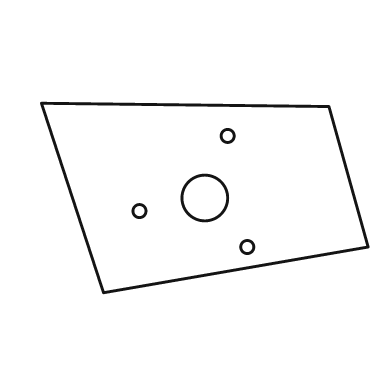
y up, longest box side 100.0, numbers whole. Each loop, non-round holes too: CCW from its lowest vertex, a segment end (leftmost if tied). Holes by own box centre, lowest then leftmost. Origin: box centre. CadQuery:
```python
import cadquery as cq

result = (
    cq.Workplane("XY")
    .moveTo(-31.0, -29.0)
    .lineTo(50.0, -15.0)
    .lineTo(38.0, 28.0)
    .lineTo(-50.0, 29.0)
    .close()
    .moveTo(13.0, -15.0)
    .circle(2.0)
    .moveTo(-20.0, -4.0)
    .circle(2.0)
    .moveTo(0.0, 0.0)
    .circle(7.0)
    .moveTo(7.0, 19.0)
    .circle(2.0)
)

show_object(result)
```